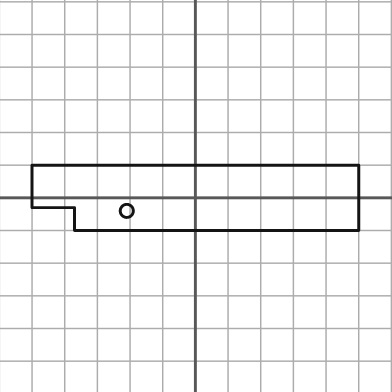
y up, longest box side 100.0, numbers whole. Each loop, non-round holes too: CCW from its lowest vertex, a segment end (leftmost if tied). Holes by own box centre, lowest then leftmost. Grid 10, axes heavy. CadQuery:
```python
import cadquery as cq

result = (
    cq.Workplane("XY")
    .moveTo(-37.0, -10.0)
    .lineTo(50.0, -10.0)
    .lineTo(50.0, 10.0)
    .lineTo(-50.0, 10.0)
    .lineTo(-50.0, -3.0)
    .lineTo(-37.0, -3.0)
    .close()
    .moveTo(-21.0, -4.0)
    .circle(2.0)
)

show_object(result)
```